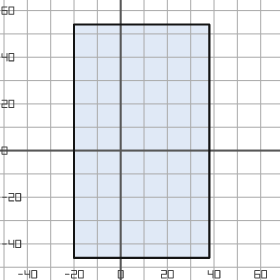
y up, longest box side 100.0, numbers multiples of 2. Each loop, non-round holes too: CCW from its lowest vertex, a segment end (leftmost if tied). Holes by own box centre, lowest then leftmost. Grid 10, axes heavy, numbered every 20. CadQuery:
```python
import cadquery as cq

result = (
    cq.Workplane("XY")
    .moveTo(-20.0, -46.0)
    .lineTo(38.0, -46.0)
    .lineTo(38.0, 54.0)
    .lineTo(-20.0, 54.0)
    .close()
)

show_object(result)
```